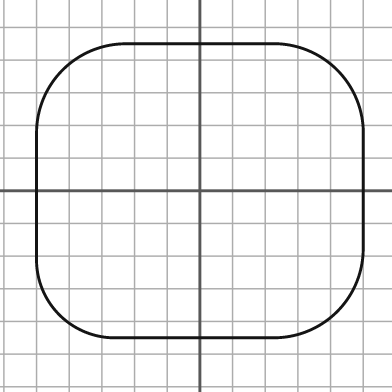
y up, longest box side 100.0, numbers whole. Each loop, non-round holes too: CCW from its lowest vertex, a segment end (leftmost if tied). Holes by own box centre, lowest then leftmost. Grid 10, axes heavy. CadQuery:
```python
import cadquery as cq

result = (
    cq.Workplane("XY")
    .moveTo(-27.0, -45.0)
    .lineTo(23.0, -45.0)
    .threePointArc((42.0, -37.0), (50.0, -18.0))
    .lineTo(50.0, 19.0)
    .threePointArc((42.0, 37.0), (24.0, 45.0))
    .lineTo(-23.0, 45.0)
    .threePointArc((-42.0, 37.0), (-50.0, 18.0))
    .lineTo(-50.0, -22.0)
    .threePointArc((-43.0, -38.0), (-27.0, -45.0))
    .close()
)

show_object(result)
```